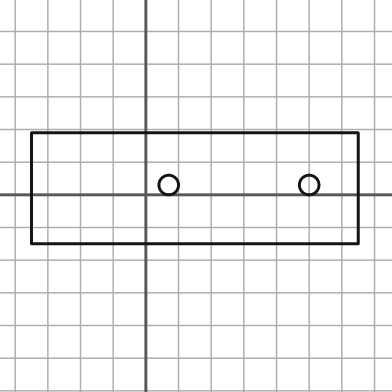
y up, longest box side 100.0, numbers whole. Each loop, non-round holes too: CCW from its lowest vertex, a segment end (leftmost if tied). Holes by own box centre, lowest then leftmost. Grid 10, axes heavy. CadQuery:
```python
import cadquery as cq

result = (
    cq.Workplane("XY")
    .moveTo(-35.0, -15.0)
    .lineTo(65.0, -15.0)
    .lineTo(65.0, 19.0)
    .lineTo(-35.0, 19.0)
    .close()
    .moveTo(7.0, 3.0)
    .circle(3.0)
    .moveTo(50.0, 3.0)
    .circle(3.0)
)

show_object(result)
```